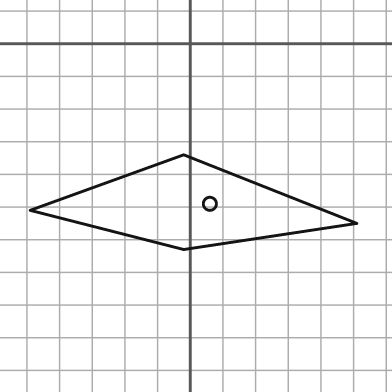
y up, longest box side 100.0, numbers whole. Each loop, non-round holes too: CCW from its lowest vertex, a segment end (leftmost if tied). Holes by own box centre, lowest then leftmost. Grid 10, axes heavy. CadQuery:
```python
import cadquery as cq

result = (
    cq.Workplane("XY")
    .moveTo(-2.0, -63.0)
    .lineTo(51.0, -55.0)
    .lineTo(-2.0, -34.0)
    .lineTo(-49.0, -51.0)
    .close()
    .moveTo(6.0, -49.0)
    .circle(2.0)
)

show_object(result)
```